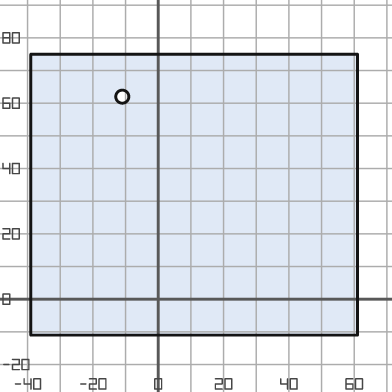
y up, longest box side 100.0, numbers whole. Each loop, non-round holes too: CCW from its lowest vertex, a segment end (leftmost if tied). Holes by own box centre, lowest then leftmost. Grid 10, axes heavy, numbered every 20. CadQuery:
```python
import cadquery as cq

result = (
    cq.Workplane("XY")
    .moveTo(-39.0, -11.0)
    .lineTo(61.0, -11.0)
    .lineTo(61.0, 75.0)
    .lineTo(-39.0, 75.0)
    .close()
    .moveTo(-11.0, 62.0)
    .circle(2.0)
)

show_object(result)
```